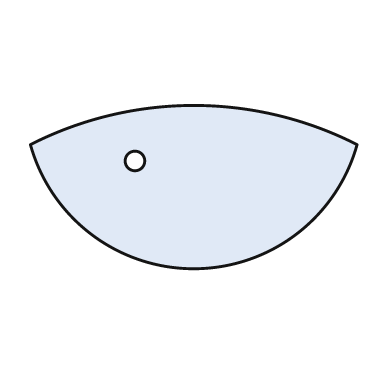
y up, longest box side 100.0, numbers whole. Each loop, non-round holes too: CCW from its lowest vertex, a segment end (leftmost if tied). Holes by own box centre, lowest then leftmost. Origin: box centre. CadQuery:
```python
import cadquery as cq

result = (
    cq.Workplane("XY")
    .moveTo(-50.0, 13.0)
    .threePointArc((0.0, -25.0), (50.0, 13.0))
    .threePointArc((0.0, 25.0), (-50.0, 13.0))
    .close()
    .moveTo(-18.0, 8.0)
    .circle(3.0)
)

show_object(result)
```